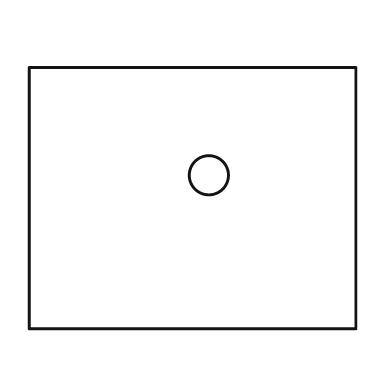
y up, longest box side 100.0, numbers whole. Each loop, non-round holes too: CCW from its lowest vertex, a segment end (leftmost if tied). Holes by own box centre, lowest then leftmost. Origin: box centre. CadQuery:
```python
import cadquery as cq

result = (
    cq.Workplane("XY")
    .moveTo(-50.0, -40.0)
    .lineTo(50.0, -40.0)
    .lineTo(50.0, 40.0)
    .lineTo(-50.0, 40.0)
    .close()
    .moveTo(5.0, 7.0)
    .circle(6.0)
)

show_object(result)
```